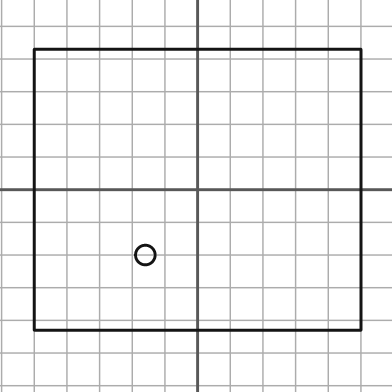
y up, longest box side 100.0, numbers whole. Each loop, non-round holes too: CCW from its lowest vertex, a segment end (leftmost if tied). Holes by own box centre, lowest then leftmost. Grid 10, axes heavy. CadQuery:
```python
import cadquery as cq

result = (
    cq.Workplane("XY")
    .moveTo(-50.0, -43.0)
    .lineTo(50.0, -43.0)
    .lineTo(50.0, 43.0)
    .lineTo(-50.0, 43.0)
    .close()
    .moveTo(-16.0, -20.0)
    .circle(3.0)
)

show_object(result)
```